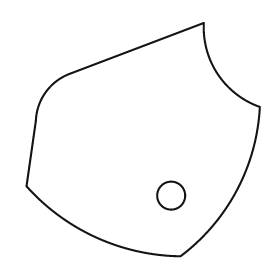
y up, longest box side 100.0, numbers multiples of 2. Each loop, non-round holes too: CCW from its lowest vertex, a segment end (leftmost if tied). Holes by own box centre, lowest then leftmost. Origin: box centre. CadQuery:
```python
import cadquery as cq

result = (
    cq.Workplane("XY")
    .moveTo(16.0, -50.0)
    .threePointArc((40.0, -22.0), (50.0, 14.0))
    .threePointArc((32.0, 28.0), (26.0, 50.0))
    .lineTo(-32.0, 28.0)
    .threePointArc((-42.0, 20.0), (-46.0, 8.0))
    .lineTo(-50.0, -20.0)
    .threePointArc((-20.0, -42.0), (16.0, -50.0))
    .close()
    .moveTo(12.0, -24.0)
    .circle(6.0)
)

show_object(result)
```